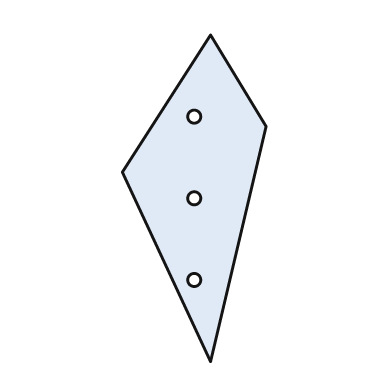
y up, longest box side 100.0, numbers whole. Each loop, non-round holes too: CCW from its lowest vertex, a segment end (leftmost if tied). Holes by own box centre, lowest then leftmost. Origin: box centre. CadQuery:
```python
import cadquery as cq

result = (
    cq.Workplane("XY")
    .moveTo(5.0, -50.0)
    .lineTo(22.0, 22.0)
    .lineTo(5.0, 50.0)
    .lineTo(-22.0, 8.0)
    .close()
    .moveTo(0.0, -25.0)
    .circle(2.0)
    .moveTo(0.0, 0.0)
    .circle(2.0)
    .moveTo(0.0, 25.0)
    .circle(2.0)
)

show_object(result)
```